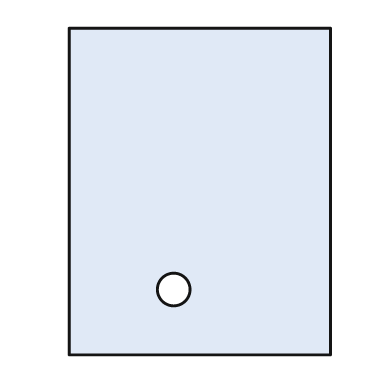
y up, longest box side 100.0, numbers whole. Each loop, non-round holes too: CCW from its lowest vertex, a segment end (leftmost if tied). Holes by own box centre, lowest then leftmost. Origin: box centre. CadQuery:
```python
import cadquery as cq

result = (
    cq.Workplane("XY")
    .moveTo(-40.0, -50.0)
    .lineTo(40.0, -50.0)
    .lineTo(40.0, 50.0)
    .lineTo(-40.0, 50.0)
    .close()
    .moveTo(-8.0, -30.0)
    .circle(5.0)
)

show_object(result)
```